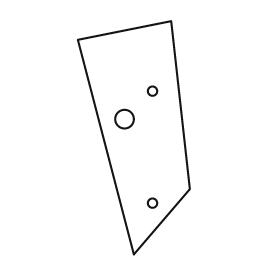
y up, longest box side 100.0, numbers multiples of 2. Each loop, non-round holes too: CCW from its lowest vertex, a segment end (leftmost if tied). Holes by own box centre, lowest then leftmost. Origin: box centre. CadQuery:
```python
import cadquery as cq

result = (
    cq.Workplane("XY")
    .moveTo(0.0, -50.0)
    .lineTo(24.0, -22.0)
    .lineTo(16.0, 50.0)
    .lineTo(-24.0, 42.0)
    .close()
    .moveTo(8.0, -28.0)
    .circle(2.0)
    .moveTo(-4.0, 8.0)
    .circle(4.0)
    .moveTo(8.0, 20.0)
    .circle(2.0)
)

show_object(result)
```